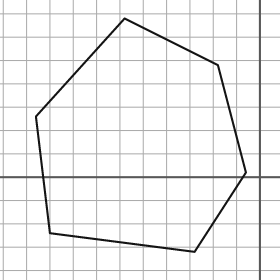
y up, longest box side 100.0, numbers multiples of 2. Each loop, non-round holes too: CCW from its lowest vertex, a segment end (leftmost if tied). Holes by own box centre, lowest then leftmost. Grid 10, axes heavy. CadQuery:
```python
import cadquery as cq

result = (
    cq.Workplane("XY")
    .moveTo(-28.0, -32.0)
    .lineTo(-6.0, 2.0)
    .lineTo(-18.0, 48.0)
    .lineTo(-58.0, 68.0)
    .lineTo(-96.0, 26.0)
    .lineTo(-90.0, -24.0)
    .close()
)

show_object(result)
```